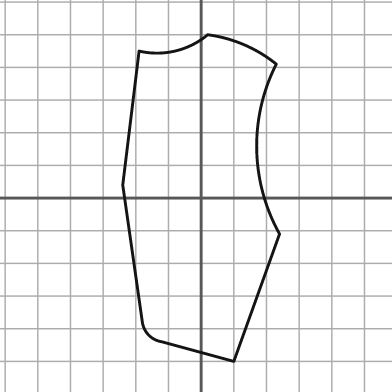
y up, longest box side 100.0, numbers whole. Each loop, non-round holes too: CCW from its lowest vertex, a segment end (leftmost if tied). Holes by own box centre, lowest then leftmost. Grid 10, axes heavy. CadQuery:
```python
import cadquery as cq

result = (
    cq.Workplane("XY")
    .moveTo(10.0, -50.0)
    .lineTo(24.0, -11.0)
    .threePointArc((17.0, 15.0), (23.0, 41.0))
    .threePointArc((13.0, 47.0), (2.0, 50.0))
    .threePointArc((-8.0, 45.0), (-19.0, 45.0))
    .lineTo(-24.0, 4.0)
    .lineTo(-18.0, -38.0)
    .threePointArc((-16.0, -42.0), (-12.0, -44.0))
    .close()
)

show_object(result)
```